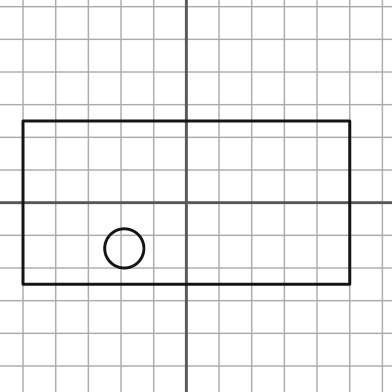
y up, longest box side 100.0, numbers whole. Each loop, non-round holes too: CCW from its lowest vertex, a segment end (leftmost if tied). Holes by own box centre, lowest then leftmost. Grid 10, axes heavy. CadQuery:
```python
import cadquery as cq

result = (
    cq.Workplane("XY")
    .moveTo(-50.0, -25.0)
    .lineTo(50.0, -25.0)
    .lineTo(50.0, 25.0)
    .lineTo(-50.0, 25.0)
    .close()
    .moveTo(-19.0, -14.0)
    .circle(6.0)
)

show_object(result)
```